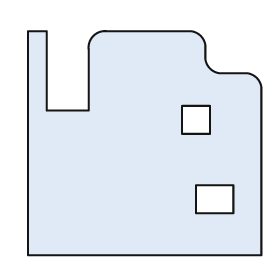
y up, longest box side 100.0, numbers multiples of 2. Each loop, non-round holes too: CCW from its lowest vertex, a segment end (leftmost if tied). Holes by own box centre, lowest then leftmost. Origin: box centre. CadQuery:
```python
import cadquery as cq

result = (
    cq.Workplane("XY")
    .moveTo(-50.0, -48.0)
    .lineTo(50.0, -48.0)
    .lineTo(50.0, 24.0)
    .threePointArc((48.0, 28.0), (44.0, 30.0))
    .lineTo(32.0, 30.0)
    .threePointArc((28.0, 32.0), (26.0, 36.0))
    .lineTo(26.0, 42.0)
    .threePointArc((24.0, 46.0), (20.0, 48.0))
    .lineTo(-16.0, 48.0)
    .threePointArc((-22.0, 46.0), (-24.0, 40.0))
    .lineTo(-24.0, 14.0)
    .lineTo(-42.0, 14.0)
    .lineTo(-42.0, 48.0)
    .lineTo(-50.0, 48.0)
    .close()
    .moveTo(22.0, -30.0)
    .lineTo(38.0, -30.0)
    .lineTo(38.0, -18.0)
    .lineTo(22.0, -18.0)
    .close()
    .moveTo(16.0, 4.0)
    .lineTo(28.0, 4.0)
    .lineTo(28.0, 16.0)
    .lineTo(16.0, 16.0)
    .close()
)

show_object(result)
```